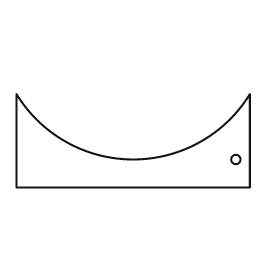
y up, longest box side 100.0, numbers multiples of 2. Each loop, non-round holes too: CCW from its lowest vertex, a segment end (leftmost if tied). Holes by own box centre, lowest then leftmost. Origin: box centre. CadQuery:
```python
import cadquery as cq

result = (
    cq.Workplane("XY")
    .moveTo(-50.0, -20.0)
    .lineTo(50.0, -20.0)
    .lineTo(50.0, 20.0)
    .threePointArc((0.0, -8.0), (-50.0, 20.0))
    .close()
    .moveTo(44.0, -8.0)
    .circle(2.0)
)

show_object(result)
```